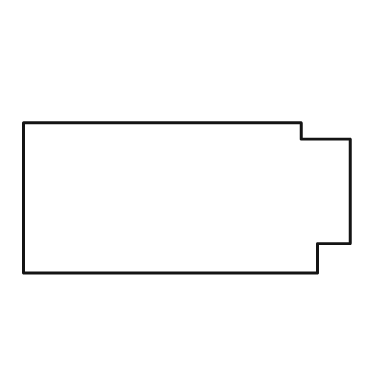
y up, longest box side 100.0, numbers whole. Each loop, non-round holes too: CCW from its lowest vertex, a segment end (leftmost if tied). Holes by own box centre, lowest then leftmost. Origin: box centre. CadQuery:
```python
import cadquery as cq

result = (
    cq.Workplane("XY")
    .moveTo(-50.0, -23.0)
    .lineTo(40.0, -23.0)
    .lineTo(40.0, -14.0)
    .lineTo(50.0, -14.0)
    .lineTo(50.0, 18.0)
    .lineTo(35.0, 18.0)
    .lineTo(35.0, 23.0)
    .lineTo(-50.0, 23.0)
    .close()
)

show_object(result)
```